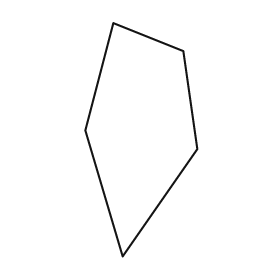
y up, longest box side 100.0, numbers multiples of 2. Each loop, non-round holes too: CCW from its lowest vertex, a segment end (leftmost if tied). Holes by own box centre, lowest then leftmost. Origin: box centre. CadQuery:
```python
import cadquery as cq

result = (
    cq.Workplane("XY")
    .moveTo(-8.0, -50.0)
    .lineTo(24.0, -4.0)
    .lineTo(18.0, 38.0)
    .lineTo(-12.0, 50.0)
    .lineTo(-24.0, 4.0)
    .close()
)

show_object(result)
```